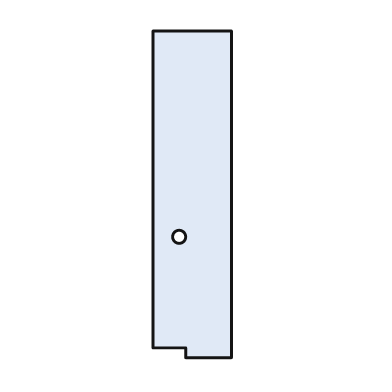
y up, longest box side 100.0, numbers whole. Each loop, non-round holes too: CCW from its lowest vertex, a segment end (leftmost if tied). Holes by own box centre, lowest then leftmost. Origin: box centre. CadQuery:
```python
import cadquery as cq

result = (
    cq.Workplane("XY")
    .moveTo(-2.0, -50.0)
    .lineTo(12.0, -50.0)
    .lineTo(12.0, 50.0)
    .lineTo(-12.0, 50.0)
    .lineTo(-12.0, -47.0)
    .lineTo(-2.0, -47.0)
    .close()
    .moveTo(-4.0, -13.0)
    .circle(2.0)
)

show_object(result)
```